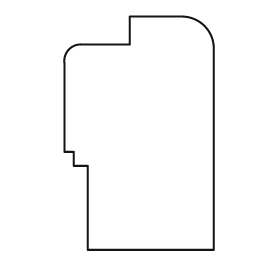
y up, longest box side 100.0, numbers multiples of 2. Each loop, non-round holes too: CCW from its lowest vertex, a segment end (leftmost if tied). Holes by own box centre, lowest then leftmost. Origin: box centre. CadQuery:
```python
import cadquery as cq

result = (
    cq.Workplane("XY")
    .moveTo(-22.0, -50.0)
    .lineTo(32.0, -50.0)
    .lineTo(32.0, 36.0)
    .threePointArc((28.0, 46.0), (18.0, 50.0))
    .lineTo(-4.0, 50.0)
    .lineTo(-4.0, 38.0)
    .lineTo(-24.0, 38.0)
    .threePointArc((-30.0, 36.0), (-32.0, 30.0))
    .lineTo(-32.0, -8.0)
    .lineTo(-28.0, -8.0)
    .lineTo(-28.0, -14.0)
    .lineTo(-22.0, -14.0)
    .close()
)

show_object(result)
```